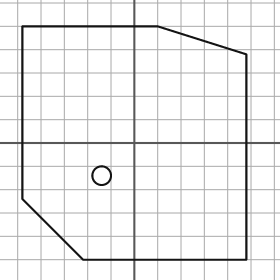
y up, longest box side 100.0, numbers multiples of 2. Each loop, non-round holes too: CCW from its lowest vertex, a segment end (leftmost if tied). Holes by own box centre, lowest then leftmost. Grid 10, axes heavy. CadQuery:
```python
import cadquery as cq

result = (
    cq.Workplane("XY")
    .moveTo(-22.0, -50.0)
    .lineTo(48.0, -50.0)
    .lineTo(48.0, 38.0)
    .lineTo(10.0, 50.0)
    .lineTo(-48.0, 50.0)
    .lineTo(-48.0, -24.0)
    .close()
    .moveTo(-14.0, -14.0)
    .circle(4.0)
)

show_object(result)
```